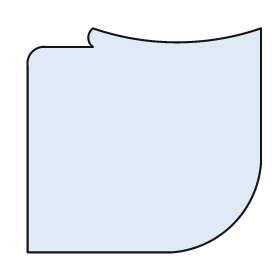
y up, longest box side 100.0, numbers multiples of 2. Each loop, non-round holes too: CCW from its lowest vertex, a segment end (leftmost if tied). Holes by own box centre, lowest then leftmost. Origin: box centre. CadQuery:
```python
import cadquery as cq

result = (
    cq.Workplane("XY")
    .moveTo(-50.0, -48.0)
    .lineTo(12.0, -48.0)
    .threePointArc((38.0, -36.0), (50.0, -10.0))
    .lineTo(50.0, 48.0)
    .threePointArc((14.0, 42.0), (-22.0, 48.0))
    .threePointArc((-24.0, 44.0), (-22.0, 40.0))
    .lineTo(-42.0, 40.0)
    .threePointArc((-48.0, 38.0), (-50.0, 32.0))
    .close()
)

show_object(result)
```